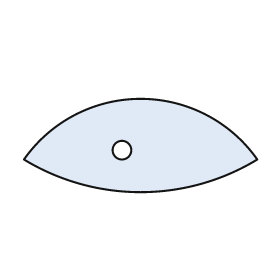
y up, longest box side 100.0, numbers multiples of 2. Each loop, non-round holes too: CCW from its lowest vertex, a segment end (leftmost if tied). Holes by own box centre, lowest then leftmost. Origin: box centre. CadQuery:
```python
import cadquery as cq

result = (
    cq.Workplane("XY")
    .moveTo(-50.0, -6.0)
    .threePointArc((0.0, -20.0), (50.0, -6.0))
    .threePointArc((0.0, 20.0), (-50.0, -6.0))
    .close()
    .moveTo(-8.0, -2.0)
    .circle(4.0)
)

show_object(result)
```